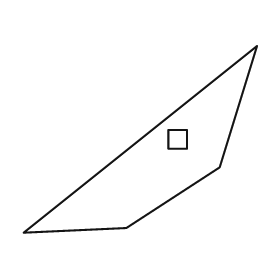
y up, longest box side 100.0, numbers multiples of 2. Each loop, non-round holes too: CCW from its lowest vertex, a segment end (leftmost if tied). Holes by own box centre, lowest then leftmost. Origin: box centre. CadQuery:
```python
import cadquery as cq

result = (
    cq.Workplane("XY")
    .moveTo(-50.0, -40.0)
    .lineTo(-6.0, -38.0)
    .lineTo(34.0, -12.0)
    .lineTo(50.0, 40.0)
    .close()
    .moveTo(12.0, -4.0)
    .lineTo(20.0, -4.0)
    .lineTo(20.0, 4.0)
    .lineTo(12.0, 4.0)
    .close()
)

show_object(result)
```